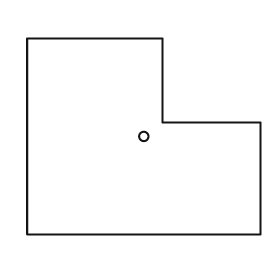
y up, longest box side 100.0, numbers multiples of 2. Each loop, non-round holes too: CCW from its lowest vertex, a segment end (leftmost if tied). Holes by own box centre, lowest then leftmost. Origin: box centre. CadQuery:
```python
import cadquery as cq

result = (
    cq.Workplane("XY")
    .moveTo(-50.0, -42.0)
    .lineTo(50.0, -42.0)
    .lineTo(50.0, 6.0)
    .lineTo(8.0, 6.0)
    .lineTo(8.0, 42.0)
    .lineTo(-50.0, 42.0)
    .close()
    .moveTo(0.0, 0.0)
    .circle(2.0)
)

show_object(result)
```